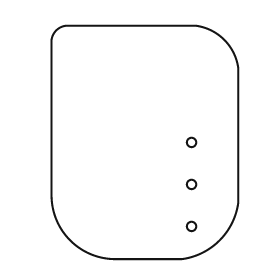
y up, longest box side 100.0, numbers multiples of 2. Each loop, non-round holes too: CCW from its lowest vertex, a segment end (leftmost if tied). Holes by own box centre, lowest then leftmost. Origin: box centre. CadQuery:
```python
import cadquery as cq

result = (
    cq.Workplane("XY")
    .moveTo(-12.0, -50.0)
    .lineTo(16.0, -50.0)
    .threePointArc((32.0, -42.0), (40.0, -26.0))
    .lineTo(40.0, 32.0)
    .threePointArc((34.0, 44.0), (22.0, 50.0))
    .lineTo(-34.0, 50.0)
    .threePointArc((-38.0, 48.0), (-40.0, 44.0))
    .lineTo(-40.0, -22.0)
    .threePointArc((-32.0, -42.0), (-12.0, -50.0))
    .close()
    .moveTo(20.0, -36.0)
    .circle(2.0)
    .moveTo(20.0, -18.0)
    .circle(2.0)
    .moveTo(20.0, 0.0)
    .circle(2.0)
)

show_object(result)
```